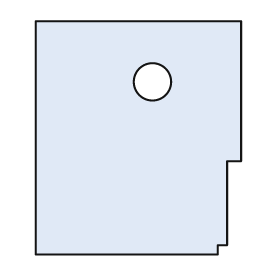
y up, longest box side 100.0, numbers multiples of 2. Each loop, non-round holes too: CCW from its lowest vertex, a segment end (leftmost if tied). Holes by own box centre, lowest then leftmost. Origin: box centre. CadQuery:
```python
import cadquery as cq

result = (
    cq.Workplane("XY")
    .moveTo(-44.0, -50.0)
    .lineTo(34.0, -50.0)
    .lineTo(34.0, -46.0)
    .lineTo(38.0, -46.0)
    .lineTo(38.0, -10.0)
    .lineTo(44.0, -10.0)
    .lineTo(44.0, 50.0)
    .lineTo(-44.0, 50.0)
    .close()
    .moveTo(6.0, 24.0)
    .circle(8.0)
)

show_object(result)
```